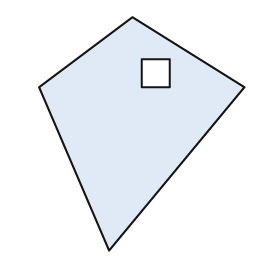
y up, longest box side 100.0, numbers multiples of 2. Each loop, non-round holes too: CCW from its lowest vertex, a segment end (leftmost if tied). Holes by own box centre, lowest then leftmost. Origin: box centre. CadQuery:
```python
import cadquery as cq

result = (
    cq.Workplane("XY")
    .moveTo(-14.0, -50.0)
    .lineTo(44.0, 20.0)
    .lineTo(-4.0, 50.0)
    .lineTo(-44.0, 20.0)
    .close()
    .moveTo(0.0, 20.0)
    .lineTo(12.0, 20.0)
    .lineTo(12.0, 32.0)
    .lineTo(0.0, 32.0)
    .close()
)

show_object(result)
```